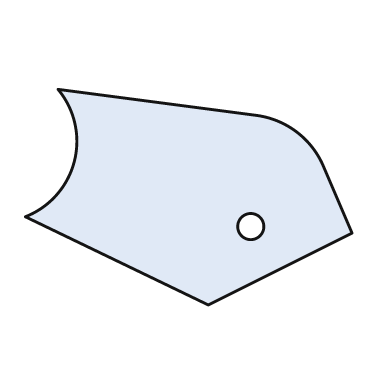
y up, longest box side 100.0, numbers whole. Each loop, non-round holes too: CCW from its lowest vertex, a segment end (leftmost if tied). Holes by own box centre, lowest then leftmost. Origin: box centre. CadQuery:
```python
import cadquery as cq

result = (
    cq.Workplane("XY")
    .moveTo(6.0, -33.0)
    .lineTo(50.0, -11.0)
    .lineTo(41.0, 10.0)
    .threePointArc((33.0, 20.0), (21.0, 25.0))
    .lineTo(-40.0, 33.0)
    .threePointArc((-35.0, 11.0), (-50.0, -6.0))
    .close()
    .moveTo(19.0, -9.0)
    .circle(4.0)
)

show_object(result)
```